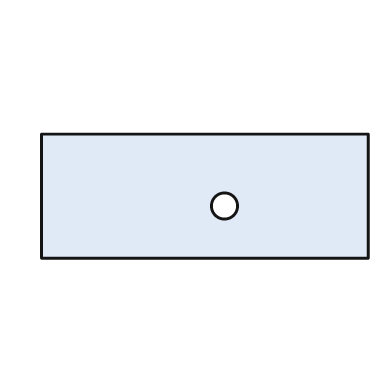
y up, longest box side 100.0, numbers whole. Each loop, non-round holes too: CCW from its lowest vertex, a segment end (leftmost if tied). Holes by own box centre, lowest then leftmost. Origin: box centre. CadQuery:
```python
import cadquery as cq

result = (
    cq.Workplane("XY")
    .moveTo(-50.0, -19.0)
    .lineTo(50.0, -19.0)
    .lineTo(50.0, 19.0)
    .lineTo(-50.0, 19.0)
    .close()
    .moveTo(6.0, -3.0)
    .circle(4.0)
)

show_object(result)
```